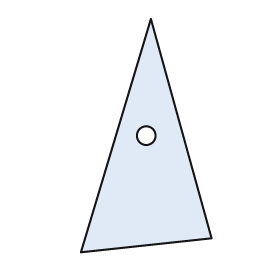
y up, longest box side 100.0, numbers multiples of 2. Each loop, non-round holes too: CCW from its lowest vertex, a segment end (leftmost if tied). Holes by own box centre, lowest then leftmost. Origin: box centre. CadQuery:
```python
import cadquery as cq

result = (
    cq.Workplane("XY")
    .moveTo(-28.0, -50.0)
    .lineTo(28.0, -44.0)
    .lineTo(2.0, 50.0)
    .close()
    .moveTo(0.0, 0.0)
    .circle(4.0)
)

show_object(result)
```